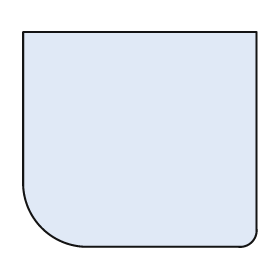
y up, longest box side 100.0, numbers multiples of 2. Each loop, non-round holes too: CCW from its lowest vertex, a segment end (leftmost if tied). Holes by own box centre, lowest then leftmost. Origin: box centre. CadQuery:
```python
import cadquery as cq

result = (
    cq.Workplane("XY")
    .moveTo(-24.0, -46.0)
    .lineTo(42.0, -46.0)
    .threePointArc((48.0, -44.0), (50.0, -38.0))
    .lineTo(50.0, 46.0)
    .lineTo(-50.0, 46.0)
    .lineTo(-50.0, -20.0)
    .threePointArc((-42.0, -38.0), (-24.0, -46.0))
    .close()
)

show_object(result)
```